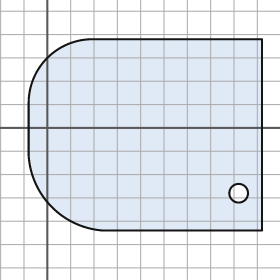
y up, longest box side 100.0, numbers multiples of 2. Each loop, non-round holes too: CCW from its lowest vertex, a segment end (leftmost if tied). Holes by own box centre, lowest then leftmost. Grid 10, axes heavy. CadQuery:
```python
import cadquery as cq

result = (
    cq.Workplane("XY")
    .moveTo(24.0, -44.0)
    .lineTo(92.0, -44.0)
    .lineTo(92.0, 38.0)
    .lineTo(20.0, 38.0)
    .threePointArc((0.0, 30.0), (-8.0, 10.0))
    .lineTo(-8.0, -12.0)
    .threePointArc((2.0, -34.0), (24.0, -44.0))
    .close()
    .moveTo(82.0, -28.0)
    .circle(4.0)
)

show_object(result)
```